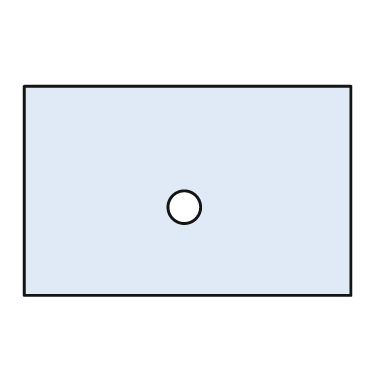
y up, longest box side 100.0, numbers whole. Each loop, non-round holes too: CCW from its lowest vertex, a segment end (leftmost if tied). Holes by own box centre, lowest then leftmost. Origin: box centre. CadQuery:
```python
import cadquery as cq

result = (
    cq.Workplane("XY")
    .moveTo(-50.0, -32.0)
    .lineTo(50.0, -32.0)
    .lineTo(50.0, 32.0)
    .lineTo(-50.0, 32.0)
    .close()
    .moveTo(-1.0, -5.0)
    .circle(5.0)
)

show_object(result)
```